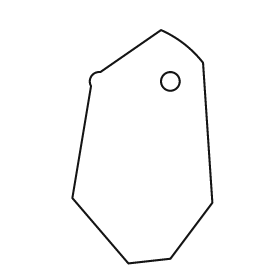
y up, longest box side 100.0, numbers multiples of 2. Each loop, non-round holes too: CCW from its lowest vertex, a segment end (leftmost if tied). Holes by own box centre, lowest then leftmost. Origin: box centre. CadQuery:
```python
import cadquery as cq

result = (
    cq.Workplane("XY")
    .moveTo(-6.0, -50.0)
    .lineTo(12.0, -48.0)
    .lineTo(30.0, -24.0)
    .lineTo(26.0, 36.0)
    .threePointArc((18.0, 44.0), (8.0, 50.0))
    .lineTo(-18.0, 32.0)
    .threePointArc((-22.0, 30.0), (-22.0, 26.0))
    .lineTo(-30.0, -22.0)
    .close()
    .moveTo(12.0, 28.0)
    .circle(4.0)
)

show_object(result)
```